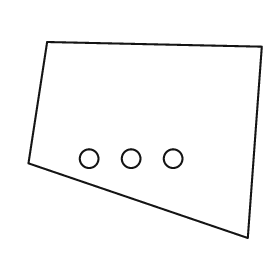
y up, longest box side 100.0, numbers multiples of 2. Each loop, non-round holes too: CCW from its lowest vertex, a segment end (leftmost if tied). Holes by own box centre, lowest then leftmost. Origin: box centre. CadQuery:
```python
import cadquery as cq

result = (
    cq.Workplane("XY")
    .moveTo(44.0, -42.0)
    .lineTo(50.0, 40.0)
    .lineTo(-42.0, 42.0)
    .lineTo(-50.0, -10.0)
    .close()
    .moveTo(-24.0, -8.0)
    .circle(4.0)
    .moveTo(-6.0, -8.0)
    .circle(4.0)
    .moveTo(12.0, -8.0)
    .circle(4.0)
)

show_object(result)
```